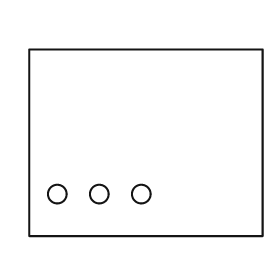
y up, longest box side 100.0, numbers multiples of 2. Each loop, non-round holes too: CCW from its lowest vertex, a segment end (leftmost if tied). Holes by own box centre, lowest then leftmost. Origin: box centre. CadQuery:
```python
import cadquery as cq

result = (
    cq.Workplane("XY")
    .moveTo(-50.0, -40.0)
    .lineTo(50.0, -40.0)
    .lineTo(50.0, 40.0)
    .lineTo(-50.0, 40.0)
    .close()
    .moveTo(-38.0, -22.0)
    .circle(4.0)
    .moveTo(-20.0, -22.0)
    .circle(4.0)
    .moveTo(-2.0, -22.0)
    .circle(4.0)
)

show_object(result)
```